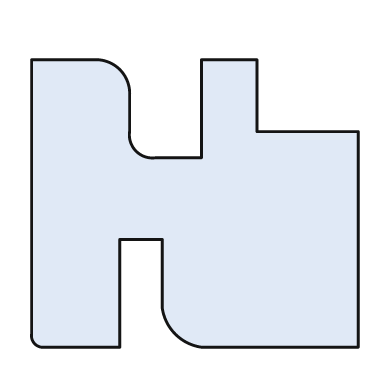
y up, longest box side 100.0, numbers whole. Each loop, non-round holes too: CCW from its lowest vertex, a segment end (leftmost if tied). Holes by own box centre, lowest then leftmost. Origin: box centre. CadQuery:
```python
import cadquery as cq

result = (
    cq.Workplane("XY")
    .moveTo(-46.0, -44.0)
    .lineTo(-23.0, -44.0)
    .lineTo(-23.0, -11.0)
    .lineTo(-10.0, -11.0)
    .lineTo(-10.0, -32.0)
    .threePointArc((-6.0, -40.0), (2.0, -44.0))
    .lineTo(50.0, -44.0)
    .lineTo(50.0, 22.0)
    .lineTo(19.0, 22.0)
    .lineTo(19.0, 44.0)
    .lineTo(2.0, 44.0)
    .lineTo(2.0, 14.0)
    .lineTo(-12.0, 14.0)
    .threePointArc((-18.0, 16.0), (-20.0, 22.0))
    .lineTo(-20.0, 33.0)
    .threePointArc((-23.0, 41.0), (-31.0, 44.0))
    .lineTo(-50.0, 44.0)
    .lineTo(-50.0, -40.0)
    .threePointArc((-49.0, -43.0), (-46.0, -44.0))
    .close()
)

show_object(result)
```